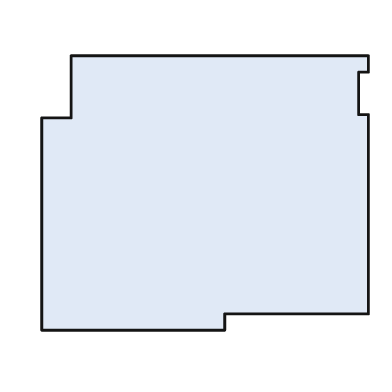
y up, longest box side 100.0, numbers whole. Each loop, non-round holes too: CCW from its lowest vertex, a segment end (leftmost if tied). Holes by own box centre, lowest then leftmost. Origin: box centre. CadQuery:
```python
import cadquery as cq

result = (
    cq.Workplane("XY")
    .moveTo(-50.0, -42.0)
    .lineTo(6.0, -42.0)
    .lineTo(6.0, -37.0)
    .lineTo(50.0, -37.0)
    .lineTo(50.0, 24.0)
    .lineTo(47.0, 24.0)
    .lineTo(47.0, 37.0)
    .lineTo(50.0, 37.0)
    .lineTo(50.0, 42.0)
    .lineTo(-41.0, 42.0)
    .lineTo(-41.0, 23.0)
    .lineTo(-50.0, 23.0)
    .close()
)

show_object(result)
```